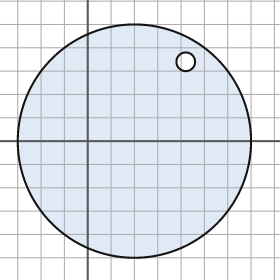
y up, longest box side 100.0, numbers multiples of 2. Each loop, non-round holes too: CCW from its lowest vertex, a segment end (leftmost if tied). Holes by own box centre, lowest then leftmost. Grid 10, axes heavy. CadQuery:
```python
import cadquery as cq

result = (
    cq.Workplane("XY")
    .moveTo(20.0, 0.0)
    .circle(50.0)
    .moveTo(42.0, 34.0)
    .circle(4.0)
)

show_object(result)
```